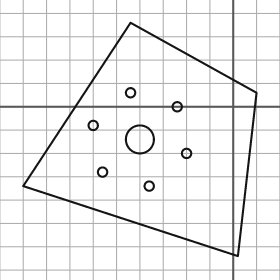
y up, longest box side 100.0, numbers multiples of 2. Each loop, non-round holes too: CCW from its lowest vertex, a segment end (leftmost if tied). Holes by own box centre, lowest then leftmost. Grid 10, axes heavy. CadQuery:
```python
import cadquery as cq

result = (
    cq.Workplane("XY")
    .moveTo(2.0, -64.0)
    .lineTo(10.0, 6.0)
    .lineTo(-44.0, 36.0)
    .lineTo(-90.0, -34.0)
    .close()
    .moveTo(-36.0, -34.0)
    .circle(2.0)
    .moveTo(-56.0, -28.0)
    .circle(2.0)
    .moveTo(-20.0, -20.0)
    .circle(2.0)
    .moveTo(-40.0, -14.0)
    .circle(6.0)
    .moveTo(-60.0, -8.0)
    .circle(2.0)
    .moveTo(-24.0, 0.0)
    .circle(2.0)
    .moveTo(-44.0, 6.0)
    .circle(2.0)
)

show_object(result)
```